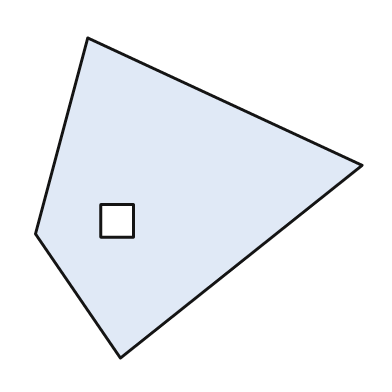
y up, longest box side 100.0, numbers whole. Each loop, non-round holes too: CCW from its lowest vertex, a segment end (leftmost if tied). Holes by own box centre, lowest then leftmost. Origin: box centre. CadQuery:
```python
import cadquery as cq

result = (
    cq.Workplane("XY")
    .moveTo(-24.0, -49.0)
    .lineTo(50.0, 10.0)
    .lineTo(-34.0, 49.0)
    .lineTo(-50.0, -11.0)
    .close()
    .moveTo(-30.0, -12.0)
    .lineTo(-20.0, -12.0)
    .lineTo(-20.0, -2.0)
    .lineTo(-30.0, -2.0)
    .close()
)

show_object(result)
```